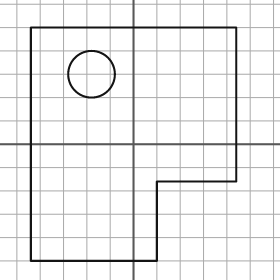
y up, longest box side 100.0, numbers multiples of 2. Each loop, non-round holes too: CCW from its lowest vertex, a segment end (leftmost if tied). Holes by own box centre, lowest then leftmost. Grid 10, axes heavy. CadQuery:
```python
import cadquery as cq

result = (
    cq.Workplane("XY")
    .moveTo(-44.0, -50.0)
    .lineTo(10.0, -50.0)
    .lineTo(10.0, -16.0)
    .lineTo(44.0, -16.0)
    .lineTo(44.0, 50.0)
    .lineTo(-44.0, 50.0)
    .close()
    .moveTo(-18.0, 30.0)
    .circle(10.0)
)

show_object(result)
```